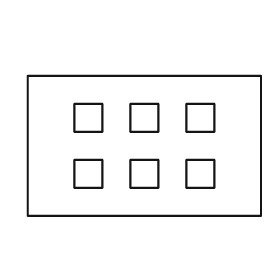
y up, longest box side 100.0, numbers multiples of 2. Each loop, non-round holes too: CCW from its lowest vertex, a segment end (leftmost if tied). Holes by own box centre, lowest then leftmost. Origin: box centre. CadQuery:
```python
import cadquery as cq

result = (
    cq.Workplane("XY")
    .moveTo(-50.0, -30.0)
    .lineTo(50.0, -30.0)
    .lineTo(50.0, 30.0)
    .lineTo(-50.0, 30.0)
    .close()
    .moveTo(-30.0, -18.0)
    .lineTo(-18.0, -18.0)
    .lineTo(-18.0, -6.0)
    .lineTo(-30.0, -6.0)
    .close()
    .moveTo(-6.0, -18.0)
    .lineTo(6.0, -18.0)
    .lineTo(6.0, -6.0)
    .lineTo(-6.0, -6.0)
    .close()
    .moveTo(18.0, -18.0)
    .lineTo(30.0, -18.0)
    .lineTo(30.0, -6.0)
    .lineTo(18.0, -6.0)
    .close()
    .moveTo(-30.0, 6.0)
    .lineTo(-18.0, 6.0)
    .lineTo(-18.0, 18.0)
    .lineTo(-30.0, 18.0)
    .close()
    .moveTo(-6.0, 6.0)
    .lineTo(6.0, 6.0)
    .lineTo(6.0, 18.0)
    .lineTo(-6.0, 18.0)
    .close()
    .moveTo(18.0, 6.0)
    .lineTo(30.0, 6.0)
    .lineTo(30.0, 18.0)
    .lineTo(18.0, 18.0)
    .close()
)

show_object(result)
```